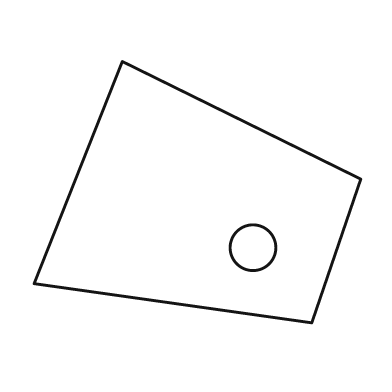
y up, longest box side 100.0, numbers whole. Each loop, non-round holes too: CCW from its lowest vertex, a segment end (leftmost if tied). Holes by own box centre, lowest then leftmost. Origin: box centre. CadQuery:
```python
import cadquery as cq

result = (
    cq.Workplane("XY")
    .moveTo(35.0, -40.0)
    .lineTo(50.0, 4.0)
    .lineTo(-23.0, 40.0)
    .lineTo(-50.0, -28.0)
    .close()
    .moveTo(17.0, -17.0)
    .circle(7.0)
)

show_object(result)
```